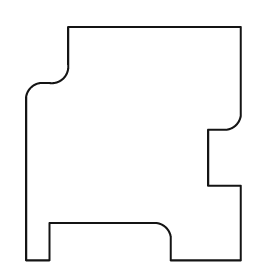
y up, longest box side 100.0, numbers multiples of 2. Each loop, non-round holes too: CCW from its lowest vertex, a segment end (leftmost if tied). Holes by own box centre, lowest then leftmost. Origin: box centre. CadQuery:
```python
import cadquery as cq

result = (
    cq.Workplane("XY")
    .moveTo(-46.0, -50.0)
    .lineTo(-36.0, -50.0)
    .lineTo(-36.0, -34.0)
    .lineTo(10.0, -34.0)
    .threePointArc((14.0, -36.0), (16.0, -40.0))
    .lineTo(16.0, -50.0)
    .lineTo(46.0, -50.0)
    .lineTo(46.0, -18.0)
    .lineTo(32.0, -18.0)
    .lineTo(32.0, 6.0)
    .lineTo(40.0, 6.0)
    .threePointArc((44.0, 8.0), (46.0, 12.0))
    .lineTo(46.0, 50.0)
    .lineTo(-28.0, 50.0)
    .lineTo(-28.0, 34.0)
    .threePointArc((-30.0, 28.0), (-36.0, 26.0))
    .lineTo(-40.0, 26.0)
    .threePointArc((-44.0, 24.0), (-46.0, 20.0))
    .close()
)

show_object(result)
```